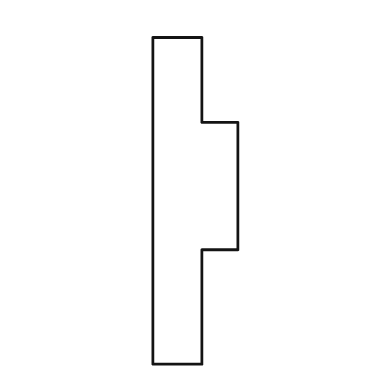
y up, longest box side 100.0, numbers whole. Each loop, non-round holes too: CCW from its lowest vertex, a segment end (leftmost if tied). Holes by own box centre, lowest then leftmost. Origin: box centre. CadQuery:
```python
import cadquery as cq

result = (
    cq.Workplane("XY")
    .moveTo(-13.0, -50.0)
    .lineTo(2.0, -50.0)
    .lineTo(2.0, -15.0)
    .lineTo(13.0, -15.0)
    .lineTo(13.0, 24.0)
    .lineTo(2.0, 24.0)
    .lineTo(2.0, 50.0)
    .lineTo(-13.0, 50.0)
    .close()
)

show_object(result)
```